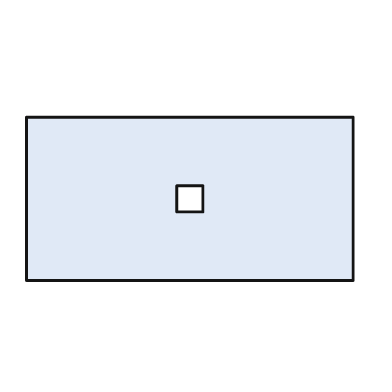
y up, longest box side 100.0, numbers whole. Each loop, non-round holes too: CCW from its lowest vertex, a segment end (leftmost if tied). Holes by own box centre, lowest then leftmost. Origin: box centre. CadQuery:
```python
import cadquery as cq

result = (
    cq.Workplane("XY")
    .moveTo(-50.0, -25.0)
    .lineTo(50.0, -25.0)
    .lineTo(50.0, 25.0)
    .lineTo(-50.0, 25.0)
    .close()
    .moveTo(-4.0, -4.0)
    .lineTo(4.0, -4.0)
    .lineTo(4.0, 4.0)
    .lineTo(-4.0, 4.0)
    .close()
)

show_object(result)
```